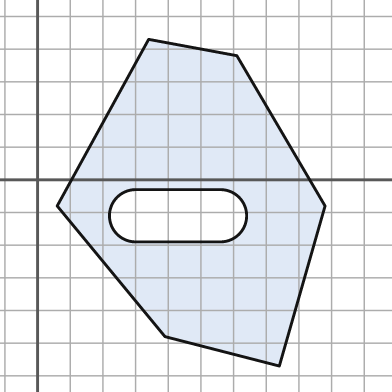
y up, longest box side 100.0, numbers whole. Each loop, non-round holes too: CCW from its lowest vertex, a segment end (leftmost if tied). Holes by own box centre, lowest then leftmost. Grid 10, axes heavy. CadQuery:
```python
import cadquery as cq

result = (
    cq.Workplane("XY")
    .moveTo(74.0, -57.0)
    .lineTo(88.0, -8.0)
    .lineTo(61.0, 38.0)
    .lineTo(34.0, 43.0)
    .lineTo(6.0, -8.0)
    .lineTo(39.0, -48.0)
    .close()
    .moveTo(30.0, -19.0)
    .lineTo(56.0, -19.0)
    .threePointArc((64.0, -11.0), (56.0, -3.0))
    .lineTo(30.0, -3.0)
    .threePointArc((22.0, -11.0), (30.0, -19.0))
    .close()
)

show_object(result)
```